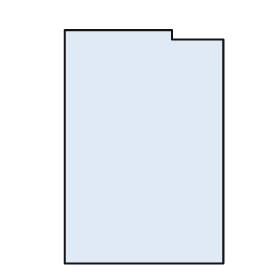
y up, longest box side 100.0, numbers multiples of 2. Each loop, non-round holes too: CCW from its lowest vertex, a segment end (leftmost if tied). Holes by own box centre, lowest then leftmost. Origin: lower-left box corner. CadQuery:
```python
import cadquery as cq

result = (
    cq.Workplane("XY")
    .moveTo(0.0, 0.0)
    .lineTo(68.0, 0.0)
    .lineTo(68.0, 96.0)
    .lineTo(46.0, 96.0)
    .lineTo(46.0, 100.0)
    .lineTo(0.0, 100.0)
    .close()
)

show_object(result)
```